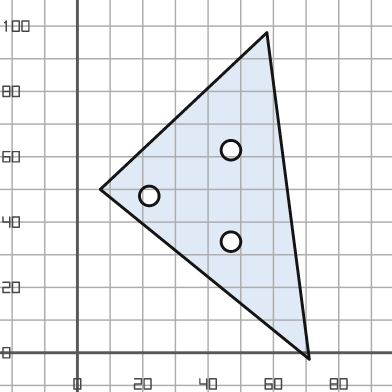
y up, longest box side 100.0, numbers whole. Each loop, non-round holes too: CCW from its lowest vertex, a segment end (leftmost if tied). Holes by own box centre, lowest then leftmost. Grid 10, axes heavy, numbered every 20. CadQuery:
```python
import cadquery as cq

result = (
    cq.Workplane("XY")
    .moveTo(71.0, -2.0)
    .lineTo(58.0, 98.0)
    .lineTo(7.0, 50.0)
    .close()
    .moveTo(47.0, 34.0)
    .circle(3.0)
    .moveTo(22.0, 48.0)
    .circle(3.0)
    .moveTo(47.0, 62.0)
    .circle(3.0)
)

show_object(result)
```